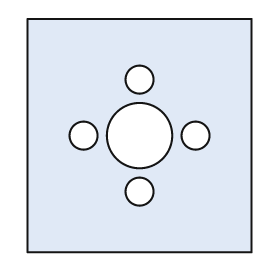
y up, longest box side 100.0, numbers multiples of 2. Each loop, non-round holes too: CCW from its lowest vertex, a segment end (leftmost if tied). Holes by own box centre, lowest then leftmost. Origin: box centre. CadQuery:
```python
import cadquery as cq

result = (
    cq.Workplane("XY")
    .moveTo(-48.0, -50.0)
    .lineTo(48.0, -50.0)
    .lineTo(48.0, 50.0)
    .lineTo(-48.0, 50.0)
    .close()
    .moveTo(0.0, -24.0)
    .circle(6.0)
    .moveTo(-24.0, 0.0)
    .circle(6.0)
    .moveTo(0.0, 0.0)
    .circle(14.0)
    .moveTo(24.0, 0.0)
    .circle(6.0)
    .moveTo(0.0, 24.0)
    .circle(6.0)
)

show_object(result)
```